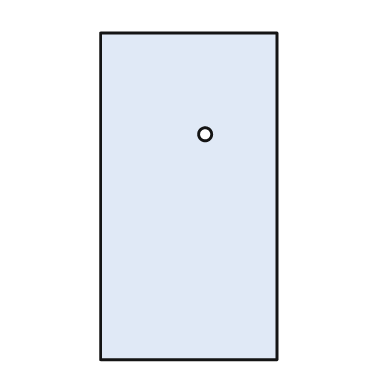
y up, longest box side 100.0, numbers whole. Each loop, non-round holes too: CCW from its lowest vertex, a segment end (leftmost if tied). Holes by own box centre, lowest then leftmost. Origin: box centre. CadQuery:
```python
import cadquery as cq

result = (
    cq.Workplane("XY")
    .moveTo(-27.0, -50.0)
    .lineTo(27.0, -50.0)
    .lineTo(27.0, 50.0)
    .lineTo(-27.0, 50.0)
    .close()
    .moveTo(5.0, 19.0)
    .circle(2.0)
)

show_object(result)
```